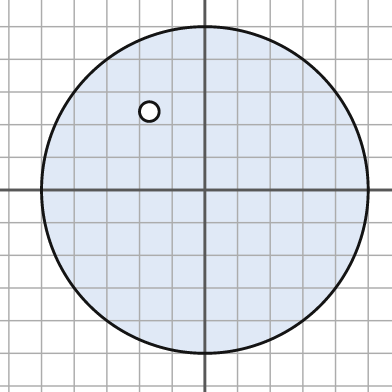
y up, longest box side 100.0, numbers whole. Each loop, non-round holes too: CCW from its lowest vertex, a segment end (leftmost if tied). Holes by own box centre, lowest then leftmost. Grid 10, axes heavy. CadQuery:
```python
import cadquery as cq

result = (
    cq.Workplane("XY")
    .moveTo(0.0, 0.0)
    .circle(50.0)
    .moveTo(-17.0, 24.0)
    .circle(3.0)
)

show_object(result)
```